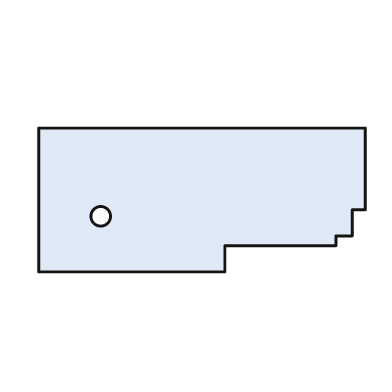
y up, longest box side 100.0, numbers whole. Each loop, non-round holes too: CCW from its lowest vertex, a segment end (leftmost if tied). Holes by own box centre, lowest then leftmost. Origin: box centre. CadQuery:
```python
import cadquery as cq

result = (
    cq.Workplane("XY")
    .moveTo(-50.0, -22.0)
    .lineTo(7.0, -22.0)
    .lineTo(7.0, -14.0)
    .lineTo(41.0, -14.0)
    .lineTo(41.0, -11.0)
    .lineTo(46.0, -11.0)
    .lineTo(46.0, -3.0)
    .lineTo(50.0, -3.0)
    .lineTo(50.0, 22.0)
    .lineTo(-50.0, 22.0)
    .close()
    .moveTo(-31.0, -5.0)
    .circle(3.0)
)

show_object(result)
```